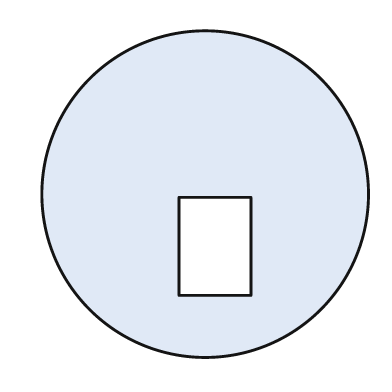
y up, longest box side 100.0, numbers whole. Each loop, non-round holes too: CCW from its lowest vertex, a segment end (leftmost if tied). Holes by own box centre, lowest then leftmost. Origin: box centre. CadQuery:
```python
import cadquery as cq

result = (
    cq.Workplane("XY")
    .moveTo(0.0, 0.0)
    .circle(50.0)
    .moveTo(-8.0, -31.0)
    .lineTo(14.0, -31.0)
    .lineTo(14.0, -1.0)
    .lineTo(-8.0, -1.0)
    .close()
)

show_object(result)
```